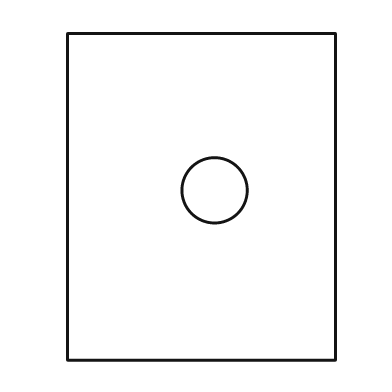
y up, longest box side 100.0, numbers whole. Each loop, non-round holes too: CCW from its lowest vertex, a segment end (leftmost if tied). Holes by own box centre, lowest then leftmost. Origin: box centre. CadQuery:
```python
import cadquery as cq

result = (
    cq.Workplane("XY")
    .moveTo(-41.0, -50.0)
    .lineTo(41.0, -50.0)
    .lineTo(41.0, 50.0)
    .lineTo(-41.0, 50.0)
    .close()
    .moveTo(4.0, 2.0)
    .circle(10.0)
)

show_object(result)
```